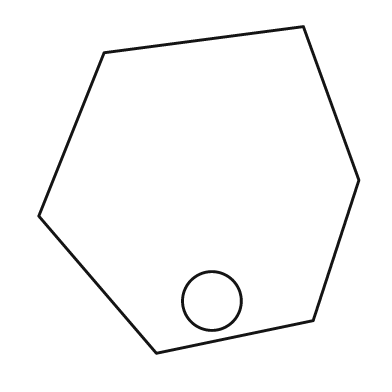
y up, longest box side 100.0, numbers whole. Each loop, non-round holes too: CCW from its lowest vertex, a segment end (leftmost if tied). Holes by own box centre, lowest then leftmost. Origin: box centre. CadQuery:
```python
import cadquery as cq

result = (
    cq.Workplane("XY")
    .moveTo(-13.0, -50.0)
    .lineTo(35.0, -40.0)
    .lineTo(49.0, 3.0)
    .lineTo(32.0, 50.0)
    .lineTo(-29.0, 42.0)
    .lineTo(-49.0, -8.0)
    .close()
    .moveTo(4.0, -34.0)
    .circle(9.0)
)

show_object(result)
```